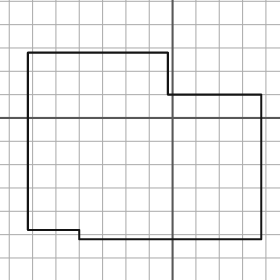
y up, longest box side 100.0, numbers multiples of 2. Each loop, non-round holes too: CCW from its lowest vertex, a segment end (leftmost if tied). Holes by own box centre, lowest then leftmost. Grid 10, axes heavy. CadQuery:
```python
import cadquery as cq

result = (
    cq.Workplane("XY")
    .moveTo(-40.0, -52.0)
    .lineTo(38.0, -52.0)
    .lineTo(38.0, 10.0)
    .lineTo(-2.0, 10.0)
    .lineTo(-2.0, 28.0)
    .lineTo(-62.0, 28.0)
    .lineTo(-62.0, -48.0)
    .lineTo(-40.0, -48.0)
    .close()
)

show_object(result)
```